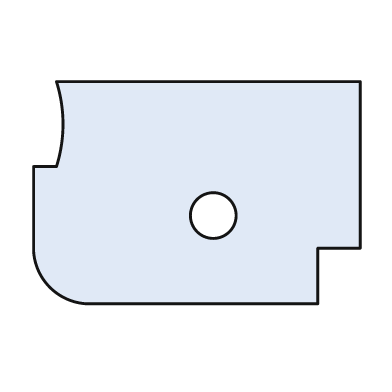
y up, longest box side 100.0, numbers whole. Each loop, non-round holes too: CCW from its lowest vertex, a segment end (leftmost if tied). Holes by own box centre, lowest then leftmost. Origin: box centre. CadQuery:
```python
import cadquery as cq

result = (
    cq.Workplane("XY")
    .moveTo(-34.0, -34.0)
    .lineTo(37.0, -34.0)
    .lineTo(37.0, -17.0)
    .lineTo(50.0, -17.0)
    .lineTo(50.0, 34.0)
    .lineTo(-43.0, 34.0)
    .threePointArc((-41.0, 21.0), (-43.0, 8.0))
    .lineTo(-50.0, 8.0)
    .lineTo(-50.0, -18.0)
    .threePointArc((-45.0, -29.0), (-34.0, -34.0))
    .close()
    .moveTo(5.0, -7.0)
    .circle(7.0)
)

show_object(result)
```